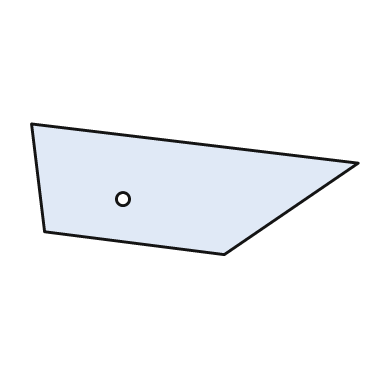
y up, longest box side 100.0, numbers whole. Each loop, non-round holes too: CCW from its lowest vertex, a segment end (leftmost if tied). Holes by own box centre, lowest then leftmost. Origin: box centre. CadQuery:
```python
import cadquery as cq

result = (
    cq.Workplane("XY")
    .moveTo(9.0, -20.0)
    .lineTo(50.0, 8.0)
    .lineTo(-50.0, 20.0)
    .lineTo(-46.0, -13.0)
    .close()
    .moveTo(-22.0, -3.0)
    .circle(2.0)
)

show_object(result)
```